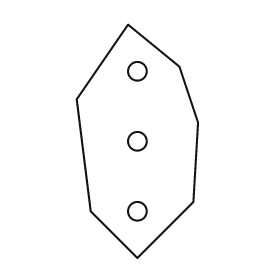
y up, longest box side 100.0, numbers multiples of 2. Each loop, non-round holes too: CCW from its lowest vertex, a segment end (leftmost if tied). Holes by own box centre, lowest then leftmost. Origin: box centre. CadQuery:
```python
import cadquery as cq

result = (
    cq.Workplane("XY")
    .moveTo(0.0, -50.0)
    .lineTo(24.0, -26.0)
    .lineTo(26.0, 8.0)
    .lineTo(18.0, 32.0)
    .lineTo(-4.0, 50.0)
    .lineTo(-26.0, 18.0)
    .lineTo(-20.0, -30.0)
    .close()
    .moveTo(0.0, -30.0)
    .circle(4.0)
    .moveTo(0.0, 0.0)
    .circle(4.0)
    .moveTo(0.0, 30.0)
    .circle(4.0)
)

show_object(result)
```